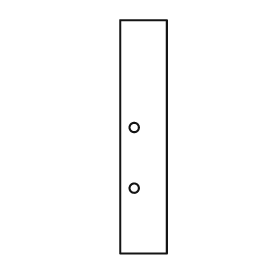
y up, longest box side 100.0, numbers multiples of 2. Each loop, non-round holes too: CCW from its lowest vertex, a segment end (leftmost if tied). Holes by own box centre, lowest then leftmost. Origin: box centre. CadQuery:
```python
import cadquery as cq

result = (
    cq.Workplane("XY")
    .moveTo(-10.0, -50.0)
    .lineTo(10.0, -50.0)
    .lineTo(10.0, 50.0)
    .lineTo(-10.0, 50.0)
    .close()
    .moveTo(-4.0, -22.0)
    .circle(2.0)
    .moveTo(-4.0, 4.0)
    .circle(2.0)
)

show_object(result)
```